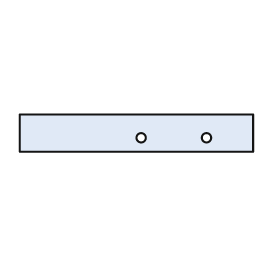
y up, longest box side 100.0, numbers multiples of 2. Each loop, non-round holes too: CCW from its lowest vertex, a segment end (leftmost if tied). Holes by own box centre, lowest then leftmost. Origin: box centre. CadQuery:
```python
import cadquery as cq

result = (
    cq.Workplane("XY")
    .moveTo(-50.0, -8.0)
    .lineTo(50.0, -8.0)
    .lineTo(50.0, 8.0)
    .lineTo(-50.0, 8.0)
    .close()
    .moveTo(2.0, -2.0)
    .circle(2.0)
    .moveTo(30.0, -2.0)
    .circle(2.0)
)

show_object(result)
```